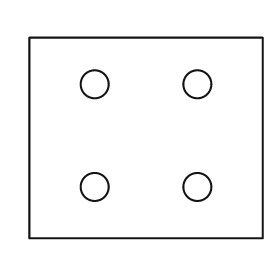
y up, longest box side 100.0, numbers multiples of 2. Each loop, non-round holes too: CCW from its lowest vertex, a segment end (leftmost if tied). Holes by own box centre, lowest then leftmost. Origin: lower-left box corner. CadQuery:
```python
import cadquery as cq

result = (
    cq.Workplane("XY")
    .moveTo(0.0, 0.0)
    .lineTo(100.0, 0.0)
    .lineTo(100.0, 86.0)
    .lineTo(0.0, 86.0)
    .close()
    .moveTo(28.0, 22.0)
    .circle(6.0)
    .moveTo(72.0, 22.0)
    .circle(6.0)
    .moveTo(28.0, 66.0)
    .circle(6.0)
    .moveTo(72.0, 66.0)
    .circle(6.0)
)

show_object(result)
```